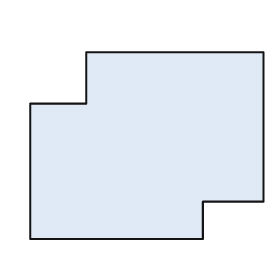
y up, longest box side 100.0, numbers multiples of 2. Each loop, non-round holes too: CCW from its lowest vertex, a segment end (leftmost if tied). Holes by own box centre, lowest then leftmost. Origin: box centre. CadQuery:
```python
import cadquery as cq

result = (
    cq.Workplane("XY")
    .moveTo(-50.0, -40.0)
    .lineTo(24.0, -40.0)
    .lineTo(24.0, -24.0)
    .lineTo(50.0, -24.0)
    .lineTo(50.0, 40.0)
    .lineTo(-26.0, 40.0)
    .lineTo(-26.0, 18.0)
    .lineTo(-50.0, 18.0)
    .close()
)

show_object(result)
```